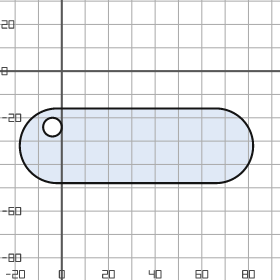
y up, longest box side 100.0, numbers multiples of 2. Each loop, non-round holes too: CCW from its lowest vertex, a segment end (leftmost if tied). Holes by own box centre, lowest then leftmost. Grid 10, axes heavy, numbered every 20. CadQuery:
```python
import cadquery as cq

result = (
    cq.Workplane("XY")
    .moveTo(-2.0, -48.0)
    .lineTo(66.0, -48.0)
    .threePointArc((82.0, -32.0), (66.0, -16.0))
    .lineTo(-2.0, -16.0)
    .threePointArc((-18.0, -32.0), (-2.0, -48.0))
    .close()
    .moveTo(-4.0, -24.0)
    .circle(4.0)
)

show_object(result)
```